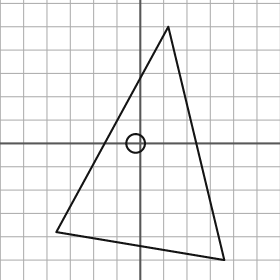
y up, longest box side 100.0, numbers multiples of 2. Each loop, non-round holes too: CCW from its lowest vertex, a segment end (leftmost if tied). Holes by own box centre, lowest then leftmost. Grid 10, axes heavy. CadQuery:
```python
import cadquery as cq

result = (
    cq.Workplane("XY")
    .moveTo(36.0, -50.0)
    .lineTo(12.0, 50.0)
    .lineTo(-36.0, -38.0)
    .close()
    .moveTo(-2.0, 0.0)
    .circle(4.0)
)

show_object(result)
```